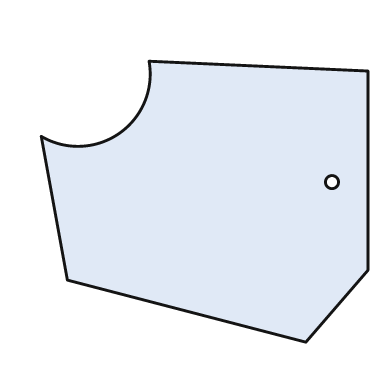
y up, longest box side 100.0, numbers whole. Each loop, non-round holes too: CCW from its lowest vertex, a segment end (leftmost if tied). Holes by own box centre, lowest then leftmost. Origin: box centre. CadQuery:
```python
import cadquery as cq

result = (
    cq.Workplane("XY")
    .moveTo(31.0, -43.0)
    .lineTo(50.0, -21.0)
    .lineTo(50.0, 40.0)
    .lineTo(-17.0, 43.0)
    .threePointArc((-26.0, 21.0), (-50.0, 20.0))
    .lineTo(-42.0, -24.0)
    .close()
    .moveTo(39.0, 6.0)
    .circle(2.0)
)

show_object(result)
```